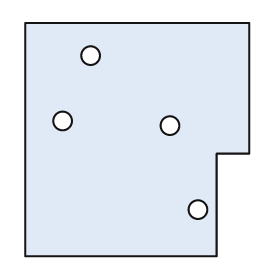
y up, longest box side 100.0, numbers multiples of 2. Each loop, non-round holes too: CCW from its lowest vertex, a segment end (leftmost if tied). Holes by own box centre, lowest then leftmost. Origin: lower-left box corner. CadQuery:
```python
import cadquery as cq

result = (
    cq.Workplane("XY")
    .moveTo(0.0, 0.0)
    .lineTo(82.0, 0.0)
    .lineTo(82.0, 44.0)
    .lineTo(96.0, 44.0)
    .lineTo(96.0, 100.0)
    .lineTo(0.0, 100.0)
    .close()
    .moveTo(74.0, 20.0)
    .circle(4.0)
    .moveTo(62.0, 56.0)
    .circle(4.0)
    .moveTo(16.0, 58.0)
    .circle(4.0)
    .moveTo(28.0, 86.0)
    .circle(4.0)
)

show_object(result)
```